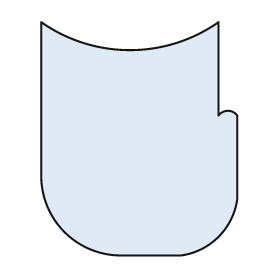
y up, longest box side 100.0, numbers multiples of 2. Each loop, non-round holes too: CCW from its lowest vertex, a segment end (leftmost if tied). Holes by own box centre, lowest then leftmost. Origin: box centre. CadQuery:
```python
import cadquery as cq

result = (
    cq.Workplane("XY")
    .moveTo(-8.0, -50.0)
    .lineTo(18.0, -50.0)
    .threePointArc((34.0, -42.0), (42.0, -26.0))
    .lineTo(42.0, 10.0)
    .threePointArc((38.0, 12.0), (34.0, 10.0))
    .lineTo(34.0, 50.0)
    .threePointArc((-4.0, 38.0), (-42.0, 50.0))
    .lineTo(-42.0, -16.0)
    .threePointArc((-32.0, -40.0), (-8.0, -50.0))
    .close()
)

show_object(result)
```